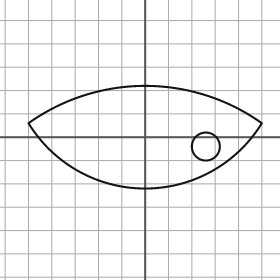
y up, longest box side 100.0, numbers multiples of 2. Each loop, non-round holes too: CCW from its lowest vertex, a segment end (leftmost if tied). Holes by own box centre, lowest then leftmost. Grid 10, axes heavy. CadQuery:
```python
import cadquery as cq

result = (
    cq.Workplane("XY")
    .moveTo(-50.0, 6.0)
    .threePointArc((0.0, -22.0), (50.0, 6.0))
    .threePointArc((0.0, 22.0), (-50.0, 6.0))
    .close()
    .moveTo(26.0, -4.0)
    .circle(6.0)
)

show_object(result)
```